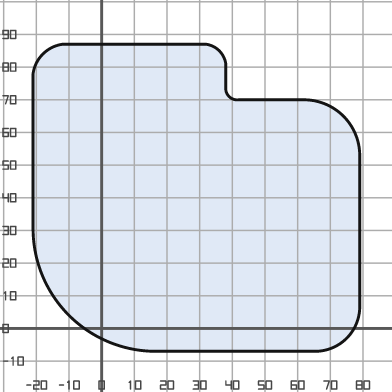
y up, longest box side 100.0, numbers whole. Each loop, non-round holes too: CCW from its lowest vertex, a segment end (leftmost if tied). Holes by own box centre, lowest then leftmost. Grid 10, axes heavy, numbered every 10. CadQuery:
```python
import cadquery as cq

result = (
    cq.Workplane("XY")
    .moveTo(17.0, -7.0)
    .lineTo(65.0, -7.0)
    .threePointArc((75.0, -3.0), (79.0, 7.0))
    .lineTo(79.0, 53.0)
    .threePointArc((74.0, 65.0), (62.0, 70.0))
    .lineTo(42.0, 70.0)
    .threePointArc((39.0, 71.0), (38.0, 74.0))
    .lineTo(38.0, 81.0)
    .threePointArc((36.0, 85.0), (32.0, 87.0))
    .lineTo(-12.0, 87.0)
    .threePointArc((-18.0, 84.0), (-21.0, 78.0))
    .lineTo(-21.0, 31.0)
    .threePointArc((-10.0, 4.0), (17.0, -7.0))
    .close()
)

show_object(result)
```